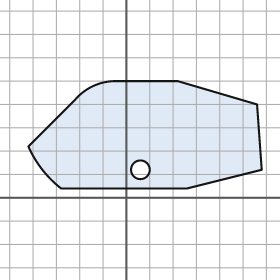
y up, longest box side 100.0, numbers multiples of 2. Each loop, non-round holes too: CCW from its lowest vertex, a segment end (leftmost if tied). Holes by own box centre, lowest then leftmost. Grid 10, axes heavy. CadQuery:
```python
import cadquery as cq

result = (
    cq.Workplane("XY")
    .moveTo(-28.0, 4.0)
    .lineTo(26.0, 4.0)
    .lineTo(58.0, 12.0)
    .lineTo(56.0, 40.0)
    .lineTo(22.0, 50.0)
    .lineTo(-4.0, 50.0)
    .threePointArc((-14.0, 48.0), (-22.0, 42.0))
    .lineTo(-42.0, 22.0)
    .threePointArc((-36.0, 12.0), (-28.0, 4.0))
    .close()
    .moveTo(6.0, 12.0)
    .circle(4.0)
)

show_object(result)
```